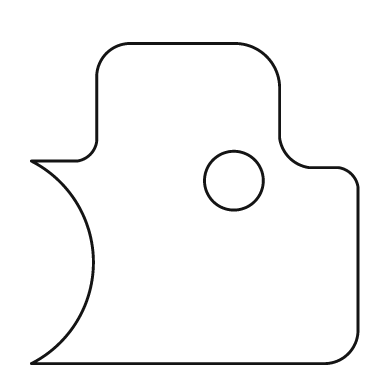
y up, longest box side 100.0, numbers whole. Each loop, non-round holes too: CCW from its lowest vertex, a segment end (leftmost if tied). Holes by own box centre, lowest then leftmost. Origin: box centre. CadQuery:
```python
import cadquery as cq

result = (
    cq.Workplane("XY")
    .moveTo(-50.0, -49.0)
    .lineTo(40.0, -49.0)
    .threePointArc((47.0, -46.0), (50.0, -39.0))
    .lineTo(50.0, 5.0)
    .threePointArc((48.0, 9.0), (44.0, 11.0))
    .lineTo(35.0, 11.0)
    .threePointArc((29.0, 14.0), (26.0, 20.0))
    .lineTo(26.0, 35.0)
    .threePointArc((22.0, 45.0), (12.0, 49.0))
    .lineTo(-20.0, 49.0)
    .threePointArc((-27.0, 46.0), (-30.0, 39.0))
    .lineTo(-30.0, 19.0)
    .threePointArc((-32.0, 15.0), (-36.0, 13.0))
    .lineTo(-50.0, 13.0)
    .threePointArc((-31.0, -18.0), (-50.0, -49.0))
    .close()
    .moveTo(12.0, 7.0)
    .circle(9.0)
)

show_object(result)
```